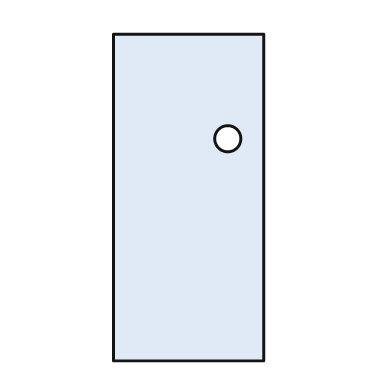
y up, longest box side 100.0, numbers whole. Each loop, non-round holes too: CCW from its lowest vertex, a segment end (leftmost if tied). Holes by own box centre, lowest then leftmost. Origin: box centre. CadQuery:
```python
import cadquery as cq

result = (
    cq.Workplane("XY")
    .moveTo(-23.0, -50.0)
    .lineTo(23.0, -50.0)
    .lineTo(23.0, 50.0)
    .lineTo(-23.0, 50.0)
    .close()
    .moveTo(12.0, 18.0)
    .circle(4.0)
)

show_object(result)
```